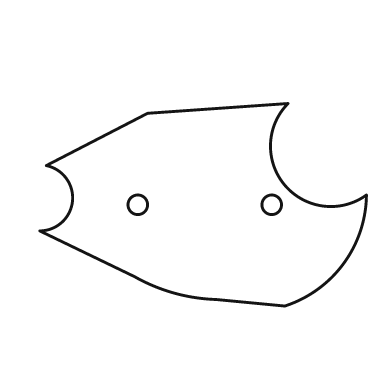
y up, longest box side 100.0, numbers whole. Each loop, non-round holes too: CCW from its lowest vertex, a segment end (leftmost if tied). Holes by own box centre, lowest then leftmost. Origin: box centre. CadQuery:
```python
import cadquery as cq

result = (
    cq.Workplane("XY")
    .moveTo(25.0, -31.0)
    .threePointArc((43.0, -18.0), (50.0, 3.0))
    .threePointArc((25.0, 6.0), (26.0, 31.0))
    .lineTo(-17.0, 28.0)
    .lineTo(-48.0, 12.0)
    .threePointArc((-40.0, 1.0), (-50.0, -8.0))
    .lineTo(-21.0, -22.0)
    .threePointArc((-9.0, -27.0), (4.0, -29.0))
    .close()
    .moveTo(-20.0, 0.0)
    .circle(3.0)
    .moveTo(21.0, 0.0)
    .circle(3.0)
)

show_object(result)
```